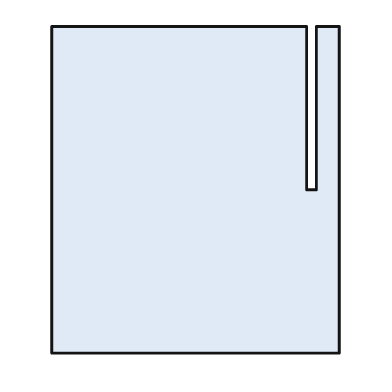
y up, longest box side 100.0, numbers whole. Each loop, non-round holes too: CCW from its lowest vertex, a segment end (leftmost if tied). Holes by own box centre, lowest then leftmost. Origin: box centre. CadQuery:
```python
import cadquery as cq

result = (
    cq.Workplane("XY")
    .moveTo(-44.0, -50.0)
    .lineTo(44.0, -50.0)
    .lineTo(44.0, 50.0)
    .lineTo(37.0, 50.0)
    .lineTo(37.0, 0.0)
    .lineTo(34.0, 0.0)
    .lineTo(34.0, 50.0)
    .lineTo(-44.0, 50.0)
    .close()
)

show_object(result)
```